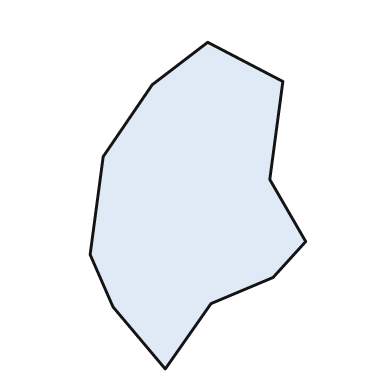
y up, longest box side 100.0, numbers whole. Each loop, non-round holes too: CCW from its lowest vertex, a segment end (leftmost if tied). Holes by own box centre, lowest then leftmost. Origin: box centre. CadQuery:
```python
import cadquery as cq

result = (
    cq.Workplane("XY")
    .moveTo(-10.0, -50.0)
    .lineTo(4.0, -30.0)
    .lineTo(23.0, -22.0)
    .lineTo(33.0, -11.0)
    .lineTo(22.0, 8.0)
    .lineTo(26.0, 38.0)
    .lineTo(3.0, 50.0)
    .lineTo(-14.0, 37.0)
    .lineTo(-29.0, 15.0)
    .lineTo(-33.0, -15.0)
    .lineTo(-26.0, -31.0)
    .close()
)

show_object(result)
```